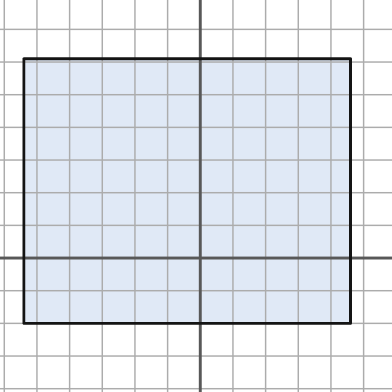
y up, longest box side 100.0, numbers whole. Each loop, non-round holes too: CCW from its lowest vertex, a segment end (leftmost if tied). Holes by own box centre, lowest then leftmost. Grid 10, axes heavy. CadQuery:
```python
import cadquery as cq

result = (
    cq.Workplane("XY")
    .moveTo(-54.0, -20.0)
    .lineTo(46.0, -20.0)
    .lineTo(46.0, 61.0)
    .lineTo(-54.0, 61.0)
    .close()
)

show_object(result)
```